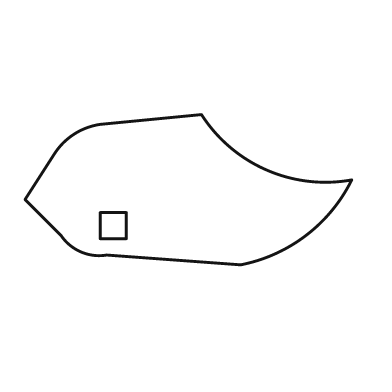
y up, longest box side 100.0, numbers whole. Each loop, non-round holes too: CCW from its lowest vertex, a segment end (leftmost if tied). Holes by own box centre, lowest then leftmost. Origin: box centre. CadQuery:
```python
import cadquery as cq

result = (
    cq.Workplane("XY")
    .moveTo(16.0, -23.0)
    .threePointArc((36.0, -14.0), (50.0, 3.0))
    .threePointArc((24.0, 6.0), (4.0, 23.0))
    .lineTo(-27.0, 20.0)
    .threePointArc((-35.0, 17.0), (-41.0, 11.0))
    .lineTo(-50.0, -3.0)
    .lineTo(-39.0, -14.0)
    .threePointArc((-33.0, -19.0), (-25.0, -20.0))
    .close()
    .moveTo(-27.0, -15.0)
    .lineTo(-19.0, -15.0)
    .lineTo(-19.0, -7.0)
    .lineTo(-27.0, -7.0)
    .close()
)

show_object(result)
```